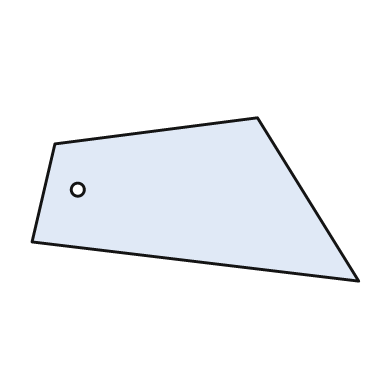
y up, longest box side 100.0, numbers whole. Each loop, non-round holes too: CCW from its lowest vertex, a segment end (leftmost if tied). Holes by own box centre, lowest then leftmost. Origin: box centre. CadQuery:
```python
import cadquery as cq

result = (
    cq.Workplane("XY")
    .moveTo(50.0, -25.0)
    .lineTo(19.0, 25.0)
    .lineTo(-43.0, 17.0)
    .lineTo(-50.0, -13.0)
    .close()
    .moveTo(-36.0, 3.0)
    .circle(2.0)
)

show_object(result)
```